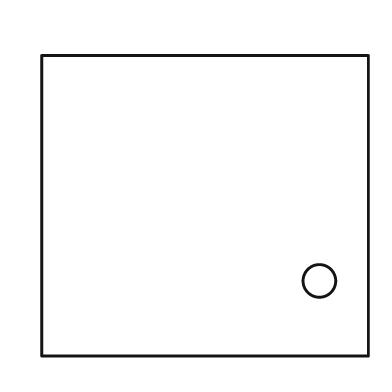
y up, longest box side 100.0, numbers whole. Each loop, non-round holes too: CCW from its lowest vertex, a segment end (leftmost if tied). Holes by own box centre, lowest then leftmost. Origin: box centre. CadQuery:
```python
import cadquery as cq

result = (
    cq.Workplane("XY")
    .moveTo(-50.0, -46.0)
    .lineTo(50.0, -46.0)
    .lineTo(50.0, 46.0)
    .lineTo(-50.0, 46.0)
    .close()
    .moveTo(35.0, -23.0)
    .circle(5.0)
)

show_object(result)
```